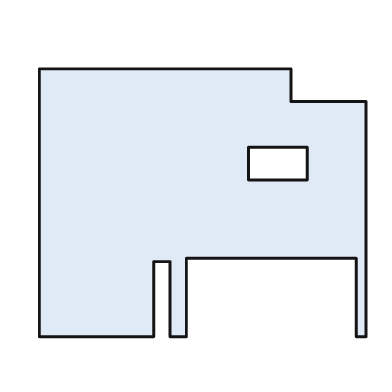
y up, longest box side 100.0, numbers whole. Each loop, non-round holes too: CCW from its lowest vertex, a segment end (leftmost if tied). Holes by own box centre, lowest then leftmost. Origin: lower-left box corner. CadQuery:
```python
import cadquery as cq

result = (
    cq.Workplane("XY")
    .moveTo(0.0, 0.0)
    .lineTo(35.0, 0.0)
    .lineTo(35.0, 23.0)
    .lineTo(40.0, 23.0)
    .lineTo(40.0, 0.0)
    .lineTo(45.0, 0.0)
    .lineTo(45.0, 24.0)
    .lineTo(97.0, 24.0)
    .lineTo(97.0, 0.0)
    .lineTo(100.0, 0.0)
    .lineTo(100.0, 72.0)
    .lineTo(77.0, 72.0)
    .lineTo(77.0, 82.0)
    .lineTo(0.0, 82.0)
    .close()
    .moveTo(64.0, 48.0)
    .lineTo(82.0, 48.0)
    .lineTo(82.0, 58.0)
    .lineTo(64.0, 58.0)
    .close()
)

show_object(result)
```